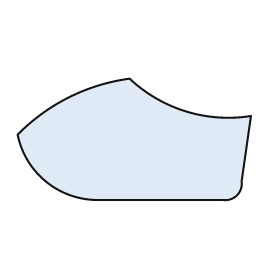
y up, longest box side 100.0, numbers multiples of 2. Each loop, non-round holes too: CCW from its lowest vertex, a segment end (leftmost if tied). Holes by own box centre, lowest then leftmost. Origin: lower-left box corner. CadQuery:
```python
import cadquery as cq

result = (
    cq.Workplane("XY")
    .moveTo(34.0, 0.0)
    .lineTo(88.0, 0.0)
    .threePointArc((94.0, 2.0), (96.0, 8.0))
    .lineTo(100.0, 36.0)
    .threePointArc((72.0, 38.0), (48.0, 52.0))
    .threePointArc((22.0, 44.0), (0.0, 28.0))
    .threePointArc((12.0, 8.0), (34.0, 0.0))
    .close()
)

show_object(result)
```